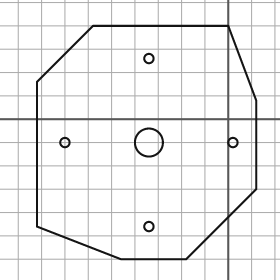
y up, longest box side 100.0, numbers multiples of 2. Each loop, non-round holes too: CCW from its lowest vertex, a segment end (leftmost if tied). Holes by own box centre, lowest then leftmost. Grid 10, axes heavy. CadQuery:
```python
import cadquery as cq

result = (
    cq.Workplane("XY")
    .moveTo(-46.0, -60.0)
    .lineTo(-18.0, -60.0)
    .lineTo(12.0, -30.0)
    .lineTo(12.0, 8.0)
    .lineTo(0.0, 40.0)
    .lineTo(-58.0, 40.0)
    .lineTo(-82.0, 16.0)
    .lineTo(-82.0, -46.0)
    .close()
    .moveTo(-34.0, -46.0)
    .circle(2.0)
    .moveTo(-70.0, -10.0)
    .circle(2.0)
    .moveTo(-34.0, -10.0)
    .circle(6.0)
    .moveTo(2.0, -10.0)
    .circle(2.0)
    .moveTo(-34.0, 26.0)
    .circle(2.0)
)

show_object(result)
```